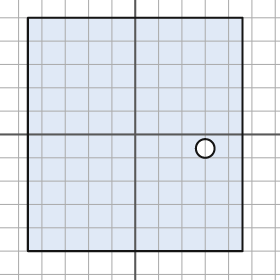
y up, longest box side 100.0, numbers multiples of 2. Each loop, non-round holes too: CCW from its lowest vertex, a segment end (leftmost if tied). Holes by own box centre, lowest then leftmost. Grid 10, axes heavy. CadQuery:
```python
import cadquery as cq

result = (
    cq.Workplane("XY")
    .moveTo(-46.0, -50.0)
    .lineTo(46.0, -50.0)
    .lineTo(46.0, 50.0)
    .lineTo(-46.0, 50.0)
    .close()
    .moveTo(30.0, -6.0)
    .circle(4.0)
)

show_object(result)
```